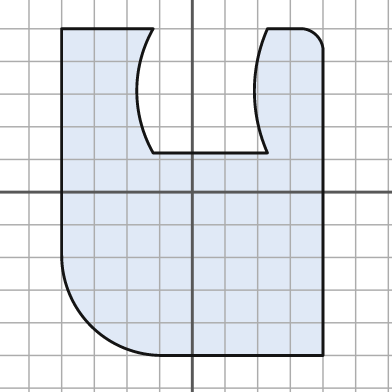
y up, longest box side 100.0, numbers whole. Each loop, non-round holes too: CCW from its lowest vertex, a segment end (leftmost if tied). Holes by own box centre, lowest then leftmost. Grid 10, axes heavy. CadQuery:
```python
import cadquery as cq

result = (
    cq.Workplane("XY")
    .moveTo(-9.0, -50.0)
    .lineTo(40.0, -50.0)
    .lineTo(40.0, 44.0)
    .threePointArc((38.0, 48.0), (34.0, 50.0))
    .lineTo(23.0, 50.0)
    .threePointArc((19.0, 31.0), (23.0, 12.0))
    .lineTo(-12.0, 12.0)
    .threePointArc((-17.0, 31.0), (-12.0, 50.0))
    .lineTo(-40.0, 50.0)
    .lineTo(-40.0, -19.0)
    .threePointArc((-31.0, -41.0), (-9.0, -50.0))
    .close()
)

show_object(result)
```